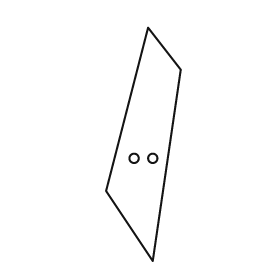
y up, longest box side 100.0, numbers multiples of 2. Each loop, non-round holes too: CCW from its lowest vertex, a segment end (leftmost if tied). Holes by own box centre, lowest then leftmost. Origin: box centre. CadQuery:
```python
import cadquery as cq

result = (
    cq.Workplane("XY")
    .moveTo(4.0, -50.0)
    .lineTo(16.0, 32.0)
    .lineTo(2.0, 50.0)
    .lineTo(-16.0, -20.0)
    .close()
    .moveTo(-4.0, -6.0)
    .circle(2.0)
    .moveTo(4.0, -6.0)
    .circle(2.0)
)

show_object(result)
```